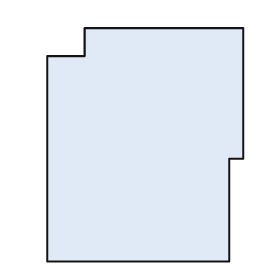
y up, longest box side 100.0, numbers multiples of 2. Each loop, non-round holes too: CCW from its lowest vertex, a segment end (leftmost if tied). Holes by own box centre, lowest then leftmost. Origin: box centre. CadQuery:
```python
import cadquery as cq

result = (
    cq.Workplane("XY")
    .moveTo(-42.0, -50.0)
    .lineTo(36.0, -50.0)
    .lineTo(36.0, -6.0)
    .lineTo(42.0, -6.0)
    .lineTo(42.0, 50.0)
    .lineTo(-26.0, 50.0)
    .lineTo(-26.0, 38.0)
    .lineTo(-42.0, 38.0)
    .close()
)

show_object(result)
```